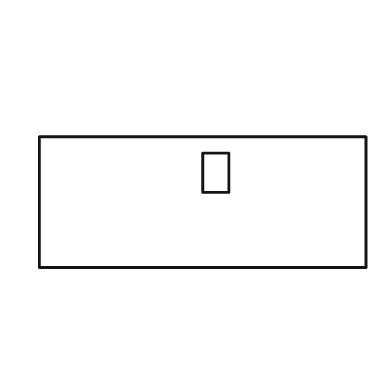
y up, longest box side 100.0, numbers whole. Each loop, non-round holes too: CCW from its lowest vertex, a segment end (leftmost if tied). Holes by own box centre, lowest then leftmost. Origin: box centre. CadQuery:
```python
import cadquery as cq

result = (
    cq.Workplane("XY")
    .moveTo(-50.0, -20.0)
    .lineTo(50.0, -20.0)
    .lineTo(50.0, 20.0)
    .lineTo(-50.0, 20.0)
    .close()
    .moveTo(0.0, 3.0)
    .lineTo(8.0, 3.0)
    .lineTo(8.0, 15.0)
    .lineTo(0.0, 15.0)
    .close()
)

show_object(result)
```